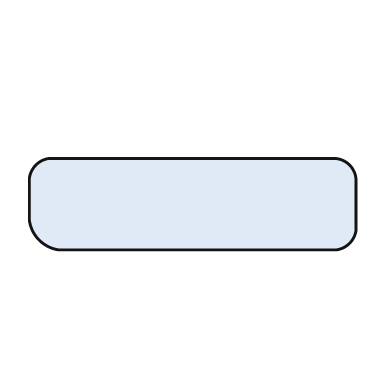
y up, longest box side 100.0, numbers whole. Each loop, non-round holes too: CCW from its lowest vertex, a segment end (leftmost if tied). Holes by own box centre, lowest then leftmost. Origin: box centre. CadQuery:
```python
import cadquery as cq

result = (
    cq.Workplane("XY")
    .moveTo(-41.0, -14.0)
    .lineTo(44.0, -14.0)
    .threePointArc((48.0, -12.0), (50.0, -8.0))
    .lineTo(50.0, 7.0)
    .threePointArc((48.0, 12.0), (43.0, 14.0))
    .lineTo(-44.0, 14.0)
    .threePointArc((-48.0, 12.0), (-50.0, 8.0))
    .lineTo(-50.0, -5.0)
    .threePointArc((-47.0, -11.0), (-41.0, -14.0))
    .close()
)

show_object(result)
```